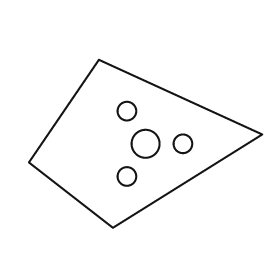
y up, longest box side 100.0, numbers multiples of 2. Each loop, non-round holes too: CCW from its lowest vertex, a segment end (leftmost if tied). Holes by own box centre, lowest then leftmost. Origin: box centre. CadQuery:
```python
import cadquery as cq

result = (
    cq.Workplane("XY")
    .moveTo(-14.0, -36.0)
    .lineTo(50.0, 4.0)
    .lineTo(-20.0, 36.0)
    .lineTo(-50.0, -8.0)
    .close()
    .moveTo(-8.0, -14.0)
    .circle(4.0)
    .moveTo(0.0, 0.0)
    .circle(6.0)
    .moveTo(16.0, 0.0)
    .circle(4.0)
    .moveTo(-8.0, 14.0)
    .circle(4.0)
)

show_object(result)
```